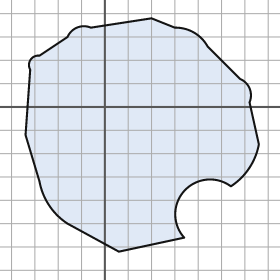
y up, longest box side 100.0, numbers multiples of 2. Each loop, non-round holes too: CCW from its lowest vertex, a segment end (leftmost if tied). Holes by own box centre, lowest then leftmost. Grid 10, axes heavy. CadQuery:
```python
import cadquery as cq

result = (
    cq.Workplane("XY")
    .moveTo(6.0, -62.0)
    .lineTo(34.0, -56.0)
    .threePointArc((34.0, -36.0), (54.0, -34.0))
    .threePointArc((62.0, -26.0), (66.0, -16.0))
    .lineTo(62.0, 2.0)
    .threePointArc((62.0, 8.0), (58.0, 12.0))
    .lineTo(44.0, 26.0)
    .threePointArc((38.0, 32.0), (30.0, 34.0))
    .lineTo(20.0, 38.0)
    .lineTo(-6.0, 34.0)
    .threePointArc((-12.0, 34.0), (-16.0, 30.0))
    .lineTo(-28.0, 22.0)
    .threePointArc((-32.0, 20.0), (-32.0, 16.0))
    .lineTo(-34.0, -12.0)
    .lineTo(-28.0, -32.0)
    .threePointArc((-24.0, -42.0), (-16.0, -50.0))
    .close()
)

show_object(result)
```